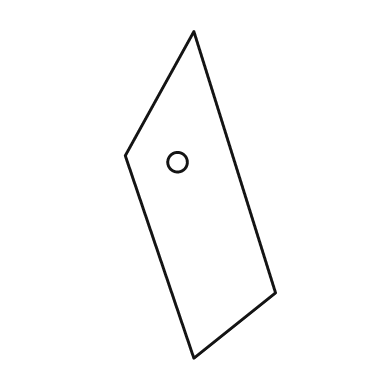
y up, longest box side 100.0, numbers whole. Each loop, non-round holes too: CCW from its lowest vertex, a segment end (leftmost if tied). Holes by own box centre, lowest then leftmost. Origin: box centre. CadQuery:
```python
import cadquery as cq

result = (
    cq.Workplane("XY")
    .moveTo(-2.0, -50.0)
    .lineTo(23.0, -30.0)
    .lineTo(-2.0, 50.0)
    .lineTo(-23.0, 12.0)
    .close()
    .moveTo(-7.0, 10.0)
    .circle(3.0)
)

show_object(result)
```